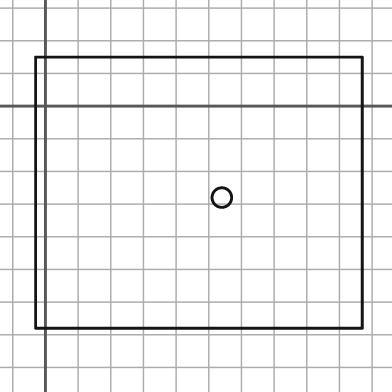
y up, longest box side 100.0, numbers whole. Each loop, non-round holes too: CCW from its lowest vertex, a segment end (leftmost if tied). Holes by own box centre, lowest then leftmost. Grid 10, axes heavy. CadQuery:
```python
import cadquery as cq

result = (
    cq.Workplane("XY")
    .moveTo(-3.0, -68.0)
    .lineTo(97.0, -68.0)
    .lineTo(97.0, 15.0)
    .lineTo(-3.0, 15.0)
    .close()
    .moveTo(54.0, -28.0)
    .circle(3.0)
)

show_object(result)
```